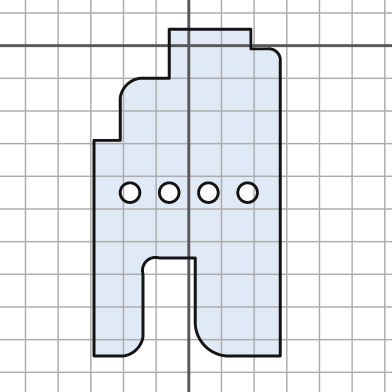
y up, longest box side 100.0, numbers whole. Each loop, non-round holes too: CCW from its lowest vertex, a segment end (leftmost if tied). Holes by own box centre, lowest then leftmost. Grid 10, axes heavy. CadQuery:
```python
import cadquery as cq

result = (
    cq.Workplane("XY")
    .moveTo(-29.0, -95.0)
    .lineTo(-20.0, -95.0)
    .threePointArc((-16.0, -93.0), (-14.0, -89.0))
    .lineTo(-14.0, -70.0)
    .threePointArc((-13.0, -66.0), (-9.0, -65.0))
    .lineTo(2.0, -65.0)
    .lineTo(2.0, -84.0)
    .threePointArc((5.0, -92.0), (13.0, -95.0))
    .lineTo(28.0, -95.0)
    .lineTo(28.0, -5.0)
    .threePointArc((27.0, -2.0), (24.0, -1.0))
    .lineTo(19.0, -1.0)
    .lineTo(19.0, 5.0)
    .lineTo(-6.0, 5.0)
    .lineTo(-6.0, -10.0)
    .lineTo(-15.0, -10.0)
    .threePointArc((-19.0, -12.0), (-21.0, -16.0))
    .lineTo(-21.0, -29.0)
    .lineTo(-29.0, -29.0)
    .close()
    .moveTo(-18.0, -45.0)
    .circle(3.0)
    .moveTo(-6.0, -45.0)
    .circle(3.0)
    .moveTo(6.0, -45.0)
    .circle(3.0)
    .moveTo(18.0, -45.0)
    .circle(3.0)
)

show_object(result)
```